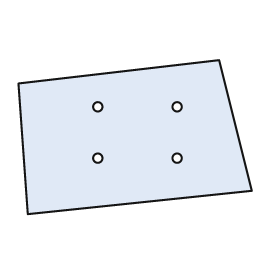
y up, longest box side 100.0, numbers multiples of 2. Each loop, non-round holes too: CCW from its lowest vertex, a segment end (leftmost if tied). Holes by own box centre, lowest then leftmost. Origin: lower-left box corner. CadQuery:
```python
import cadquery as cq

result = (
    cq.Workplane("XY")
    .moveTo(4.0, 0.0)
    .lineTo(100.0, 10.0)
    .lineTo(86.0, 66.0)
    .lineTo(0.0, 56.0)
    .close()
    .moveTo(34.0, 24.0)
    .circle(2.0)
    .moveTo(68.0, 24.0)
    .circle(2.0)
    .moveTo(34.0, 46.0)
    .circle(2.0)
    .moveTo(68.0, 46.0)
    .circle(2.0)
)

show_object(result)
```